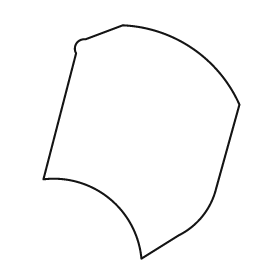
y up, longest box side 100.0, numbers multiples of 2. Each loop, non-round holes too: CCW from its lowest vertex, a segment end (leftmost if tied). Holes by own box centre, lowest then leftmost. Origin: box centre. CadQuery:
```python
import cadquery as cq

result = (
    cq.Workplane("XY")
    .moveTo(0.0, -50.0)
    .lineTo(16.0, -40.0)
    .threePointArc((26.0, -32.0), (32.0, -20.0))
    .lineTo(42.0, 16.0)
    .threePointArc((22.0, 40.0), (-8.0, 50.0))
    .lineTo(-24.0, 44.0)
    .threePointArc((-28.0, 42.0), (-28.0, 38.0))
    .lineTo(-42.0, -16.0)
    .threePointArc((-14.0, -24.0), (0.0, -50.0))
    .close()
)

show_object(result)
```